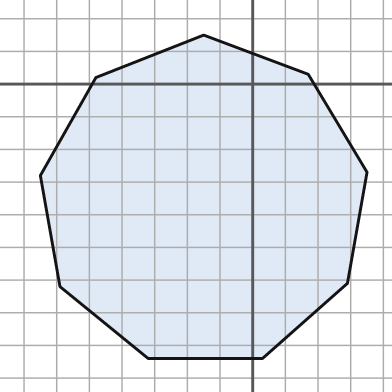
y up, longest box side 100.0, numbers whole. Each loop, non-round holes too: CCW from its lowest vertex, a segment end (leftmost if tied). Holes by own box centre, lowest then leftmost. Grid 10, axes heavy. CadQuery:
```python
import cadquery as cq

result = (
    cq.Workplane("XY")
    .moveTo(-32.0, -84.0)
    .lineTo(3.0, -84.0)
    .lineTo(29.0, -61.0)
    .lineTo(35.0, -27.0)
    .lineTo(17.0, 3.0)
    .lineTo(-15.0, 15.0)
    .lineTo(-48.0, 2.0)
    .lineTo(-65.0, -28.0)
    .lineTo(-59.0, -62.0)
    .close()
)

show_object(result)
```